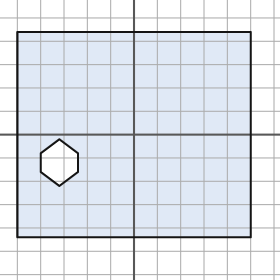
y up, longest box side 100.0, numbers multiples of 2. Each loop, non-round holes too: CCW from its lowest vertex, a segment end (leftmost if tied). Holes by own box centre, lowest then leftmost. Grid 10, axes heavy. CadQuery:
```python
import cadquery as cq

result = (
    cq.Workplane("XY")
    .moveTo(-50.0, -44.0)
    .lineTo(50.0, -44.0)
    .lineTo(50.0, 44.0)
    .lineTo(-50.0, 44.0)
    .close()
    .moveTo(-32.0, -22.0)
    .lineTo(-24.0, -16.0)
    .lineTo(-24.0, -8.0)
    .lineTo(-32.0, -2.0)
    .lineTo(-40.0, -8.0)
    .lineTo(-40.0, -16.0)
    .close()
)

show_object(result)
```